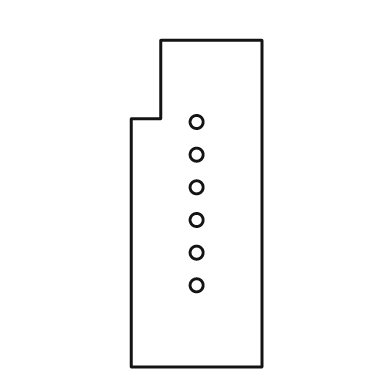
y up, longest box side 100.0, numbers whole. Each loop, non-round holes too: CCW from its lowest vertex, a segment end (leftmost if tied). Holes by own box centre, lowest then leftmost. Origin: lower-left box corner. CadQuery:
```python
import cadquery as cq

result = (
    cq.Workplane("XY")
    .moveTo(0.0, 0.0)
    .lineTo(40.0, 0.0)
    .lineTo(40.0, 100.0)
    .lineTo(9.0, 100.0)
    .lineTo(9.0, 76.0)
    .lineTo(0.0, 76.0)
    .close()
    .moveTo(20.0, 25.0)
    .circle(2.0)
    .moveTo(20.0, 35.0)
    .circle(2.0)
    .moveTo(20.0, 45.0)
    .circle(2.0)
    .moveTo(20.0, 55.0)
    .circle(2.0)
    .moveTo(20.0, 65.0)
    .circle(2.0)
    .moveTo(20.0, 75.0)
    .circle(2.0)
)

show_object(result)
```